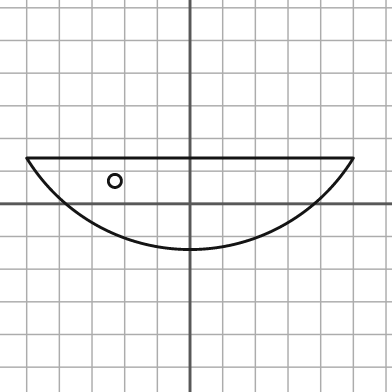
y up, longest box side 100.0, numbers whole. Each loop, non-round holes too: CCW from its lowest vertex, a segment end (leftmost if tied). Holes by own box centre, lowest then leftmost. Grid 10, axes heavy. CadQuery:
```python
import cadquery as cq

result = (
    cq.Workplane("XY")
    .moveTo(-50.0, 14.0)
    .threePointArc((0.0, -14.0), (50.0, 14.0))
    .close()
    .moveTo(-23.0, 7.0)
    .circle(2.0)
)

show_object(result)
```